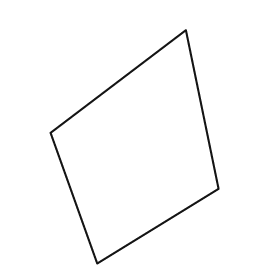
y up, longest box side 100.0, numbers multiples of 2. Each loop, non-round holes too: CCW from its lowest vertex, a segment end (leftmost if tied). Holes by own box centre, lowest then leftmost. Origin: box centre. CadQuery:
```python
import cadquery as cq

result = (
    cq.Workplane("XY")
    .moveTo(-16.0, -50.0)
    .lineTo(36.0, -18.0)
    .lineTo(22.0, 50.0)
    .lineTo(-36.0, 6.0)
    .close()
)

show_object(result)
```